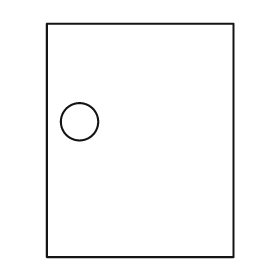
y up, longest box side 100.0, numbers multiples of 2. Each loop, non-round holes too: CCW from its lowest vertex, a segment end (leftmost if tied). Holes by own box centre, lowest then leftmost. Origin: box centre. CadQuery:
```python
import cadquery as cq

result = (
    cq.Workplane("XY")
    .moveTo(-40.0, -50.0)
    .lineTo(40.0, -50.0)
    .lineTo(40.0, 50.0)
    .lineTo(-40.0, 50.0)
    .close()
    .moveTo(-26.0, 8.0)
    .circle(8.0)
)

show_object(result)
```